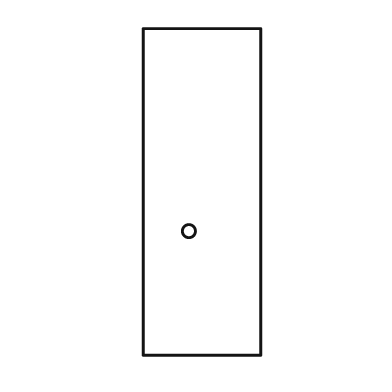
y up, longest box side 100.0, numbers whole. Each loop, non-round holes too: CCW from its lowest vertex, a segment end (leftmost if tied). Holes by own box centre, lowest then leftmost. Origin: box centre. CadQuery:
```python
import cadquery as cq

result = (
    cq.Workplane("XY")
    .moveTo(-18.0, -50.0)
    .lineTo(18.0, -50.0)
    .lineTo(18.0, 50.0)
    .lineTo(-18.0, 50.0)
    .close()
    .moveTo(-4.0, -12.0)
    .circle(2.0)
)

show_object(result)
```